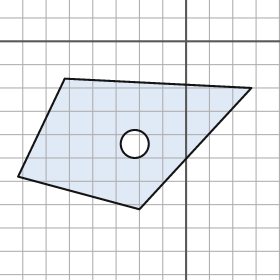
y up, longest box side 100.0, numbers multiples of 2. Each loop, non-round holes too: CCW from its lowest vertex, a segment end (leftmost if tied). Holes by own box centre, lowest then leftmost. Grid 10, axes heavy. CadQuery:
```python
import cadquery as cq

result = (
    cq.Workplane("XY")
    .moveTo(-20.0, -72.0)
    .lineTo(28.0, -20.0)
    .lineTo(-52.0, -16.0)
    .lineTo(-72.0, -58.0)
    .close()
    .moveTo(-22.0, -44.0)
    .circle(6.0)
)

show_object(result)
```